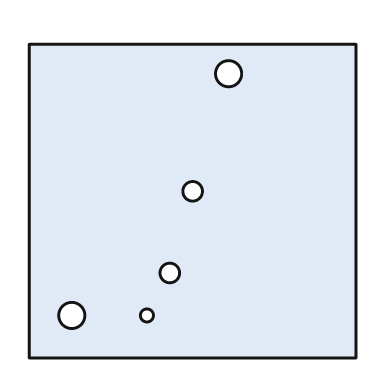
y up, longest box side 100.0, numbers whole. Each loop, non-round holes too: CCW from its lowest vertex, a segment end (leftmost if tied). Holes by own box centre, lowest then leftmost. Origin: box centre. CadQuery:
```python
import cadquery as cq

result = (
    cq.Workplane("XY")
    .moveTo(-50.0, -48.0)
    .lineTo(50.0, -48.0)
    .lineTo(50.0, 48.0)
    .lineTo(-50.0, 48.0)
    .close()
    .moveTo(-37.0, -35.0)
    .circle(4.0)
    .moveTo(-14.0, -35.0)
    .circle(2.0)
    .moveTo(-7.0, -22.0)
    .circle(3.0)
    .moveTo(0.0, 3.0)
    .circle(3.0)
    .moveTo(11.0, 39.0)
    .circle(4.0)
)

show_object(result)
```